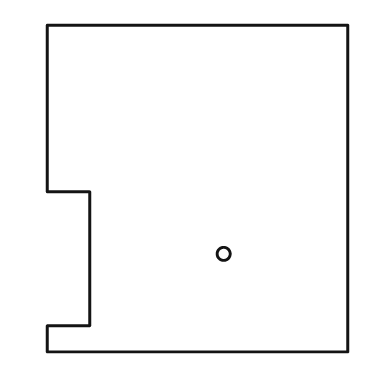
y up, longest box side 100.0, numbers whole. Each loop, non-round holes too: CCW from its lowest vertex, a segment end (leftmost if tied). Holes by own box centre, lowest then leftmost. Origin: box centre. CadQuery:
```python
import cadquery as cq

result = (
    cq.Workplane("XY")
    .moveTo(-46.0, -50.0)
    .lineTo(46.0, -50.0)
    .lineTo(46.0, 50.0)
    .lineTo(-46.0, 50.0)
    .lineTo(-46.0, -1.0)
    .lineTo(-33.0, -1.0)
    .lineTo(-33.0, -42.0)
    .lineTo(-46.0, -42.0)
    .close()
    .moveTo(8.0, -20.0)
    .circle(2.0)
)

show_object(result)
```